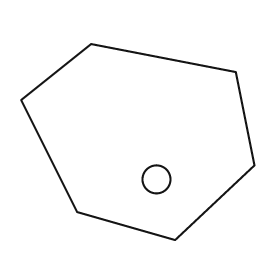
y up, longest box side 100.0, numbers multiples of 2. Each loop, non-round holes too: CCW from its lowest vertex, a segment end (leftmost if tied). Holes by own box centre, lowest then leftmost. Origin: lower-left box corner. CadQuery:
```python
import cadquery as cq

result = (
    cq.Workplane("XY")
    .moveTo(66.0, 0.0)
    .lineTo(100.0, 32.0)
    .lineTo(92.0, 72.0)
    .lineTo(30.0, 84.0)
    .lineTo(0.0, 60.0)
    .lineTo(24.0, 12.0)
    .close()
    .moveTo(58.0, 26.0)
    .circle(6.0)
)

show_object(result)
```